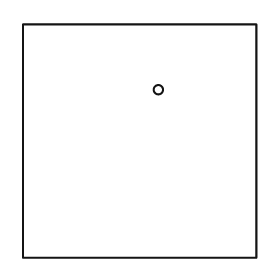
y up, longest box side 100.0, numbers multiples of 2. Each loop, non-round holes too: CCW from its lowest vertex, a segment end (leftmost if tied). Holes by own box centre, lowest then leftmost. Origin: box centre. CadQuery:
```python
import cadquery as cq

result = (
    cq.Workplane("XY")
    .moveTo(-50.0, -50.0)
    .lineTo(50.0, -50.0)
    .lineTo(50.0, 50.0)
    .lineTo(-50.0, 50.0)
    .close()
    .moveTo(8.0, 22.0)
    .circle(2.0)
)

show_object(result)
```